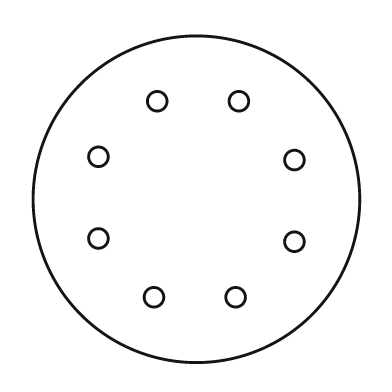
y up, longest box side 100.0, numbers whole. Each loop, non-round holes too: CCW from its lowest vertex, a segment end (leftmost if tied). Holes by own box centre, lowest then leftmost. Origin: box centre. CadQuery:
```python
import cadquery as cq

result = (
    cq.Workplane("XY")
    .moveTo(0.0, 0.0)
    .circle(50.0)
    .moveTo(-13.0, -30.0)
    .circle(3.0)
    .moveTo(12.0, -30.0)
    .circle(3.0)
    .moveTo(30.0, -13.0)
    .circle(3.0)
    .moveTo(-30.0, -12.0)
    .circle(3.0)
    .moveTo(30.0, 12.0)
    .circle(3.0)
    .moveTo(-30.0, 13.0)
    .circle(3.0)
    .moveTo(-12.0, 30.0)
    .circle(3.0)
    .moveTo(13.0, 30.0)
    .circle(3.0)
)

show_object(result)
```